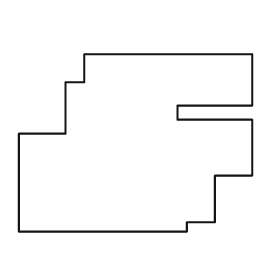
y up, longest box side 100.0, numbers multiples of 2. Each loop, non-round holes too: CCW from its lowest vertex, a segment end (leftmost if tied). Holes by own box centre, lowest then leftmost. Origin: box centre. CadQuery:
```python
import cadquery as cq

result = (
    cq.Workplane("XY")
    .moveTo(-50.0, -38.0)
    .lineTo(22.0, -38.0)
    .lineTo(22.0, -34.0)
    .lineTo(34.0, -34.0)
    .lineTo(34.0, -14.0)
    .lineTo(50.0, -14.0)
    .lineTo(50.0, 10.0)
    .lineTo(18.0, 10.0)
    .lineTo(18.0, 16.0)
    .lineTo(50.0, 16.0)
    .lineTo(50.0, 38.0)
    .lineTo(-22.0, 38.0)
    .lineTo(-22.0, 26.0)
    .lineTo(-30.0, 26.0)
    .lineTo(-30.0, 4.0)
    .lineTo(-50.0, 4.0)
    .close()
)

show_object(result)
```